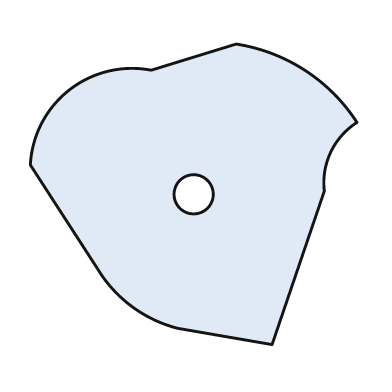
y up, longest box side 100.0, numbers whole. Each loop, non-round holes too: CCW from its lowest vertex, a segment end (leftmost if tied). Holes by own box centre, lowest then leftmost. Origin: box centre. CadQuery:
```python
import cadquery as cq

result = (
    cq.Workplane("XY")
    .moveTo(24.0, -46.0)
    .lineTo(40.0, 1.0)
    .threePointArc((42.0, 13.0), (50.0, 22.0))
    .threePointArc((34.0, 38.0), (13.0, 46.0))
    .lineTo(-13.0, 38.0)
    .threePointArc((-38.0, 32.0), (-50.0, 9.0))
    .lineTo(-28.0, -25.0)
    .threePointArc((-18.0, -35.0), (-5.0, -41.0))
    .close()
    .moveTo(0.0, 0.0)
    .circle(6.0)
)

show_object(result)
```